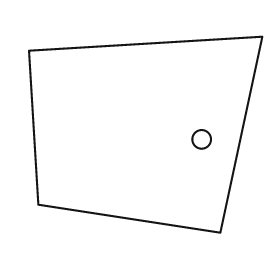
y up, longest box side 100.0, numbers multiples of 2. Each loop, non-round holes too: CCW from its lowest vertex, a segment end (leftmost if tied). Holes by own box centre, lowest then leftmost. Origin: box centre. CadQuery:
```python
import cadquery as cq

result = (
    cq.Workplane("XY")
    .moveTo(32.0, -42.0)
    .lineTo(50.0, 42.0)
    .lineTo(-50.0, 36.0)
    .lineTo(-46.0, -30.0)
    .close()
    .moveTo(24.0, -2.0)
    .circle(4.0)
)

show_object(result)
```